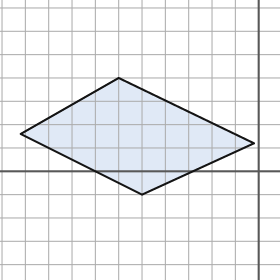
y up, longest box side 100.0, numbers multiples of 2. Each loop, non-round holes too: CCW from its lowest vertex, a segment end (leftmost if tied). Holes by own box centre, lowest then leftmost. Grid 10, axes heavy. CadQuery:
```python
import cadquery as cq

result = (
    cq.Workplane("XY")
    .moveTo(-50.0, -10.0)
    .lineTo(-2.0, 12.0)
    .lineTo(-60.0, 40.0)
    .lineTo(-102.0, 16.0)
    .close()
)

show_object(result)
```